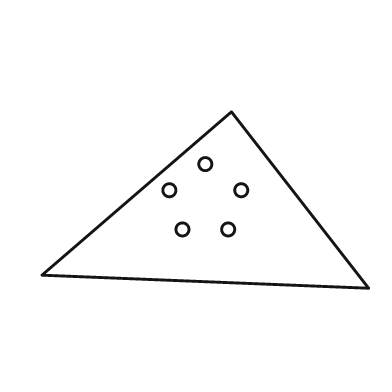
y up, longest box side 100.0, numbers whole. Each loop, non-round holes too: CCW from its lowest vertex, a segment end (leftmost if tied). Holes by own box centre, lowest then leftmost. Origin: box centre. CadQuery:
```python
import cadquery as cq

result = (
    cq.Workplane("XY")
    .moveTo(50.0, -27.0)
    .lineTo(8.0, 27.0)
    .lineTo(-50.0, -23.0)
    .close()
    .moveTo(-7.0, -9.0)
    .circle(2.0)
    .moveTo(7.0, -9.0)
    .circle(2.0)
    .moveTo(-11.0, 3.0)
    .circle(2.0)
    .moveTo(11.0, 3.0)
    .circle(2.0)
    .moveTo(0.0, 11.0)
    .circle(2.0)
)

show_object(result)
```